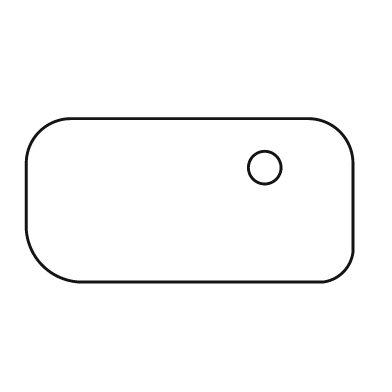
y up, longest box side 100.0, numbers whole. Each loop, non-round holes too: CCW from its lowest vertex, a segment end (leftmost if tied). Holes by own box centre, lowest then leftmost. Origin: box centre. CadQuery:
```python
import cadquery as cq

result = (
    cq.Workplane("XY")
    .moveTo(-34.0, -25.0)
    .lineTo(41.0, -25.0)
    .threePointArc((47.0, -22.0), (50.0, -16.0))
    .lineTo(50.0, 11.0)
    .threePointArc((46.0, 21.0), (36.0, 25.0))
    .lineTo(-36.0, 25.0)
    .threePointArc((-46.0, 21.0), (-50.0, 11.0))
    .lineTo(-50.0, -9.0)
    .threePointArc((-45.0, -20.0), (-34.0, -25.0))
    .close()
    .moveTo(23.0, 10.0)
    .circle(5.0)
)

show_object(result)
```